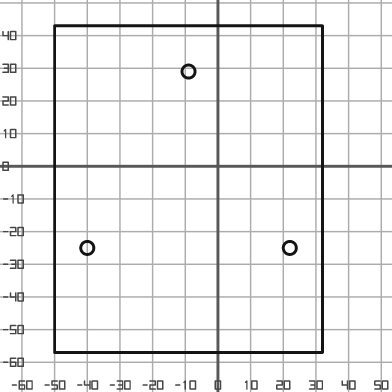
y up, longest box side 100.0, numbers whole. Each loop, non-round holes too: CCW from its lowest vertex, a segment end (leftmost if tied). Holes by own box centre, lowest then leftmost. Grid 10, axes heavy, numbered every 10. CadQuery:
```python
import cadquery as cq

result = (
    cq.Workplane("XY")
    .moveTo(-50.0, -57.0)
    .lineTo(32.0, -57.0)
    .lineTo(32.0, 43.0)
    .lineTo(-50.0, 43.0)
    .close()
    .moveTo(-40.0, -25.0)
    .circle(2.0)
    .moveTo(22.0, -25.0)
    .circle(2.0)
    .moveTo(-9.0, 29.0)
    .circle(2.0)
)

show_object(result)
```